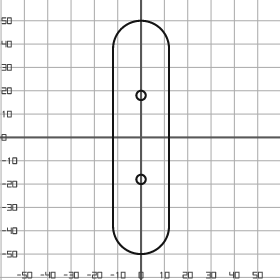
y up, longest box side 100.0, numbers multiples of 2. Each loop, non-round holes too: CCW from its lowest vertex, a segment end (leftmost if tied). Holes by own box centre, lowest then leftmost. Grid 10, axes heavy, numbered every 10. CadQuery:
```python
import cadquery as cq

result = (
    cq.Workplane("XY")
    .moveTo(-12.0, -38.0)
    .threePointArc((0.0, -50.0), (12.0, -38.0))
    .lineTo(12.0, 38.0)
    .threePointArc((0.0, 50.0), (-12.0, 38.0))
    .close()
    .moveTo(0.0, -18.0)
    .circle(2.0)
    .moveTo(0.0, 18.0)
    .circle(2.0)
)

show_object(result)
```